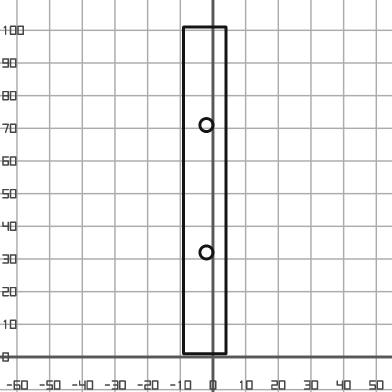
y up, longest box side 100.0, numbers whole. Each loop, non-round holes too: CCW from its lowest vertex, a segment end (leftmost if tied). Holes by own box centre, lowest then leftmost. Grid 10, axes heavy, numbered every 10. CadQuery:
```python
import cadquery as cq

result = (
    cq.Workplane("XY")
    .moveTo(-9.0, 1.0)
    .lineTo(4.0, 1.0)
    .lineTo(4.0, 101.0)
    .lineTo(-9.0, 101.0)
    .close()
    .moveTo(-2.0, 32.0)
    .circle(2.0)
    .moveTo(-2.0, 71.0)
    .circle(2.0)
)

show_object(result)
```